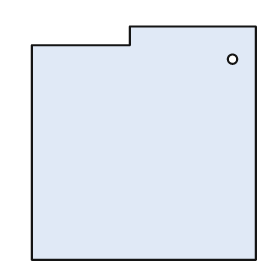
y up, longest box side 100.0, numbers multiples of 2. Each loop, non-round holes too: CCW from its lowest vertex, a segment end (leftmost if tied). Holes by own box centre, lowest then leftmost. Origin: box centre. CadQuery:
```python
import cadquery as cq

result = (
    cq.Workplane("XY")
    .moveTo(-48.0, -50.0)
    .lineTo(48.0, -50.0)
    .lineTo(48.0, 50.0)
    .lineTo(-6.0, 50.0)
    .lineTo(-6.0, 42.0)
    .lineTo(-48.0, 42.0)
    .close()
    .moveTo(38.0, 36.0)
    .circle(2.0)
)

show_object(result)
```